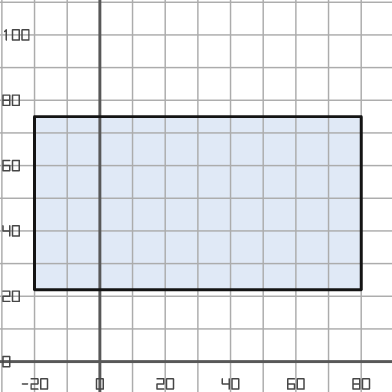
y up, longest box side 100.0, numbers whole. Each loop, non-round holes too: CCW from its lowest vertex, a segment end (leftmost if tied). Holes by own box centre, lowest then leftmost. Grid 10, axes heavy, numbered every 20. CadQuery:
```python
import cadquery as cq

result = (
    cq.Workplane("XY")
    .moveTo(-20.0, 22.0)
    .lineTo(80.0, 22.0)
    .lineTo(80.0, 75.0)
    .lineTo(-20.0, 75.0)
    .close()
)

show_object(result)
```